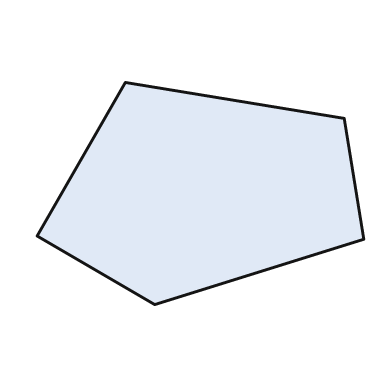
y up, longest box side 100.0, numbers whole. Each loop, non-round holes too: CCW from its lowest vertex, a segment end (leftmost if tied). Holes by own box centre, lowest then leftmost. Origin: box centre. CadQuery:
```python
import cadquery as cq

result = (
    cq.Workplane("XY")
    .moveTo(-14.0, -34.0)
    .lineTo(50.0, -14.0)
    .lineTo(44.0, 23.0)
    .lineTo(-23.0, 34.0)
    .lineTo(-50.0, -13.0)
    .close()
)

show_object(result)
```